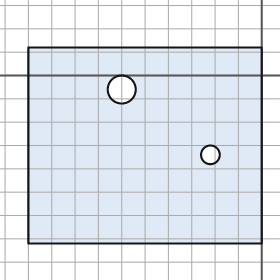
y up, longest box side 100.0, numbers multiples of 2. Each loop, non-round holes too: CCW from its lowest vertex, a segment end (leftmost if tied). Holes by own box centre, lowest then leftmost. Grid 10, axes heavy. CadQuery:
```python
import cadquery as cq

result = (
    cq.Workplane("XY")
    .moveTo(-100.0, -72.0)
    .lineTo(0.0, -72.0)
    .lineTo(0.0, 12.0)
    .lineTo(-100.0, 12.0)
    .close()
    .moveTo(-22.0, -34.0)
    .circle(4.0)
    .moveTo(-60.0, -6.0)
    .circle(6.0)
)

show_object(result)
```